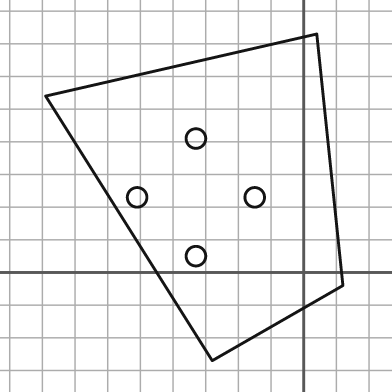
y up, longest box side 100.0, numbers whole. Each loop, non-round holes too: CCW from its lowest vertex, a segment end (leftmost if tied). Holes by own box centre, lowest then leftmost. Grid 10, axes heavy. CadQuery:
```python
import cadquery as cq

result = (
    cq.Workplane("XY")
    .moveTo(-28.0, -27.0)
    .lineTo(12.0, -4.0)
    .lineTo(4.0, 73.0)
    .lineTo(-79.0, 54.0)
    .close()
    .moveTo(-33.0, 5.0)
    .circle(3.0)
    .moveTo(-51.0, 23.0)
    .circle(3.0)
    .moveTo(-15.0, 23.0)
    .circle(3.0)
    .moveTo(-33.0, 41.0)
    .circle(3.0)
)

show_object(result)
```